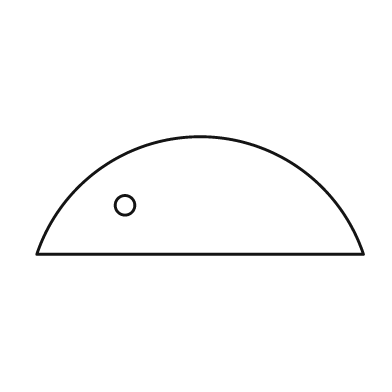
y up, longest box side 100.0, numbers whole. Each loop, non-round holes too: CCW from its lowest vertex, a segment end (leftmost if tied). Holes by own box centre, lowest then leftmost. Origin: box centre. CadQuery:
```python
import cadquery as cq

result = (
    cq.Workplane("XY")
    .moveTo(-50.0, -18.0)
    .lineTo(50.0, -18.0)
    .threePointArc((0.0, 18.0), (-50.0, -18.0))
    .close()
    .moveTo(-23.0, -3.0)
    .circle(3.0)
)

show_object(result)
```